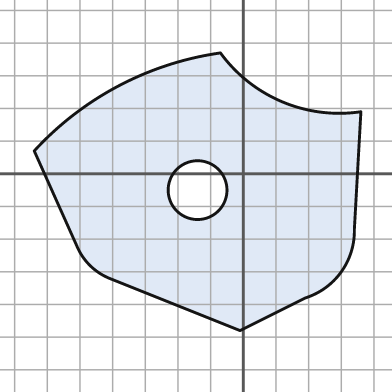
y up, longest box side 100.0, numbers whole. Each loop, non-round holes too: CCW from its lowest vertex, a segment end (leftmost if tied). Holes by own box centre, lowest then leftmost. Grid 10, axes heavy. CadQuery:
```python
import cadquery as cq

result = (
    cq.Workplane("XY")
    .moveTo(-1.0, -48.0)
    .lineTo(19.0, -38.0)
    .threePointArc((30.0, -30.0), (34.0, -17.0))
    .lineTo(36.0, 19.0)
    .threePointArc((12.0, 22.0), (-7.0, 37.0))
    .threePointArc((-38.0, 27.0), (-64.0, 7.0))
    .lineTo(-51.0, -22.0)
    .threePointArc((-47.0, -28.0), (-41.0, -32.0))
    .close()
    .moveTo(-14.0, -5.0)
    .circle(9.0)
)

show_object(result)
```